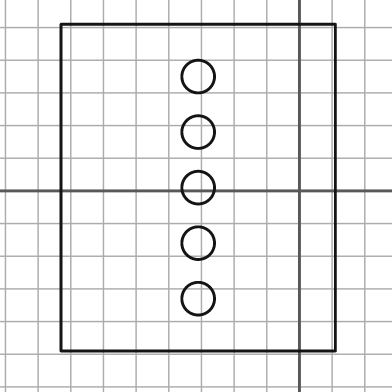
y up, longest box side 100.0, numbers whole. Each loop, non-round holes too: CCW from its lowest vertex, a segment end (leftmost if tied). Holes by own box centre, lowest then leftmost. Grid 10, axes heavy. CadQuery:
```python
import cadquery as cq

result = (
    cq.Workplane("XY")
    .moveTo(-73.0, -49.0)
    .lineTo(11.0, -49.0)
    .lineTo(11.0, 51.0)
    .lineTo(-73.0, 51.0)
    .close()
    .moveTo(-31.0, -33.0)
    .circle(5.0)
    .moveTo(-31.0, -16.0)
    .circle(5.0)
    .moveTo(-31.0, 1.0)
    .circle(5.0)
    .moveTo(-31.0, 18.0)
    .circle(5.0)
    .moveTo(-31.0, 35.0)
    .circle(5.0)
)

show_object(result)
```